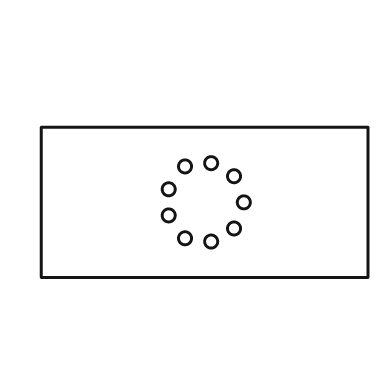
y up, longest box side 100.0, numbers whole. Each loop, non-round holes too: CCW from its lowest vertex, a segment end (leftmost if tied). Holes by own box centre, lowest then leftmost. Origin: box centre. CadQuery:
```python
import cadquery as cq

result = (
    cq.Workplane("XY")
    .moveTo(-50.0, -23.0)
    .lineTo(50.0, -23.0)
    .lineTo(50.0, 23.0)
    .lineTo(-50.0, 23.0)
    .close()
    .moveTo(2.0, -12.0)
    .circle(2.0)
    .moveTo(-6.0, -11.0)
    .circle(2.0)
    .moveTo(9.0, -8.0)
    .circle(2.0)
    .moveTo(-11.0, -4.0)
    .circle(2.0)
    .moveTo(12.0, 0.0)
    .circle(2.0)
    .moveTo(-11.0, 4.0)
    .circle(2.0)
    .moveTo(9.0, 8.0)
    .circle(2.0)
    .moveTo(-6.0, 11.0)
    .circle(2.0)
    .moveTo(2.0, 12.0)
    .circle(2.0)
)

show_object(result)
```